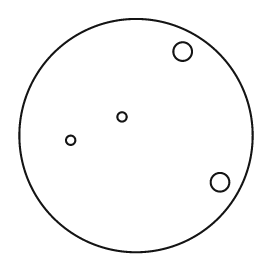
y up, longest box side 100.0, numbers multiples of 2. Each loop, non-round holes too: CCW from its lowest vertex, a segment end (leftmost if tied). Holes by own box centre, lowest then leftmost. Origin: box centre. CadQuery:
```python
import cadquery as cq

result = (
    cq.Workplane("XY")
    .moveTo(0.0, 0.0)
    .circle(50.0)
    .moveTo(36.0, -20.0)
    .circle(4.0)
    .moveTo(-28.0, -2.0)
    .circle(2.0)
    .moveTo(-6.0, 8.0)
    .circle(2.0)
    .moveTo(20.0, 36.0)
    .circle(4.0)
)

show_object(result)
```